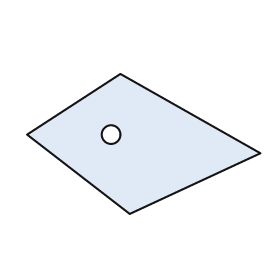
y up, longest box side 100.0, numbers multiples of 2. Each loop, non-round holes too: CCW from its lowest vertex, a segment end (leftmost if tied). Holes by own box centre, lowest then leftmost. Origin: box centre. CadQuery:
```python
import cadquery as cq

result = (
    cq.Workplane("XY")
    .moveTo(-6.0, -30.0)
    .lineTo(50.0, -4.0)
    .lineTo(-10.0, 30.0)
    .lineTo(-50.0, 4.0)
    .close()
    .moveTo(-14.0, 4.0)
    .circle(4.0)
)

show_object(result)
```